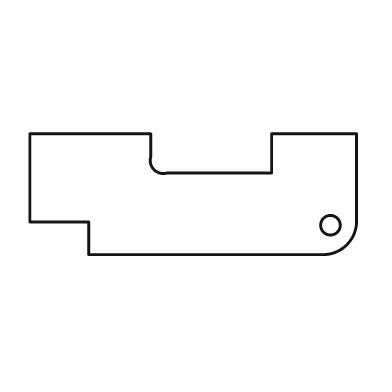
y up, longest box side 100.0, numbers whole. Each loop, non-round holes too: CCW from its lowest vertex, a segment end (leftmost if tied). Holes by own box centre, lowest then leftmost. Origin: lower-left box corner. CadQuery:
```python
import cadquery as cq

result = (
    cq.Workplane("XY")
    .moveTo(18.0, 0.0)
    .lineTo(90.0, 0.0)
    .threePointArc((97.0, 3.0), (100.0, 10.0))
    .lineTo(100.0, 37.0)
    .lineTo(74.0, 37.0)
    .lineTo(74.0, 25.0)
    .lineTo(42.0, 25.0)
    .threePointArc((38.0, 26.0), (37.0, 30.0))
    .lineTo(37.0, 37.0)
    .lineTo(0.0, 37.0)
    .lineTo(0.0, 10.0)
    .lineTo(18.0, 10.0)
    .close()
    .moveTo(92.0, 9.0)
    .circle(3.0)
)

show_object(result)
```